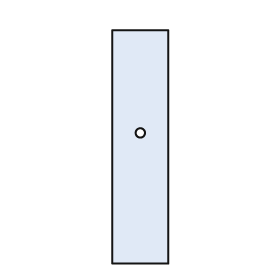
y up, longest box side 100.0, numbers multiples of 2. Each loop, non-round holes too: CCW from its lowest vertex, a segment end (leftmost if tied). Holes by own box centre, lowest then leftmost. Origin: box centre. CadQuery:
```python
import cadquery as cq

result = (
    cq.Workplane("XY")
    .moveTo(-12.0, -50.0)
    .lineTo(12.0, -50.0)
    .lineTo(12.0, 50.0)
    .lineTo(-12.0, 50.0)
    .close()
    .moveTo(0.0, 6.0)
    .circle(2.0)
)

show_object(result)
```